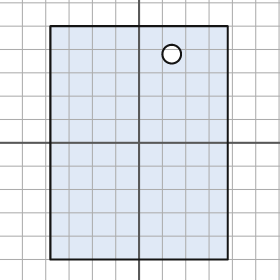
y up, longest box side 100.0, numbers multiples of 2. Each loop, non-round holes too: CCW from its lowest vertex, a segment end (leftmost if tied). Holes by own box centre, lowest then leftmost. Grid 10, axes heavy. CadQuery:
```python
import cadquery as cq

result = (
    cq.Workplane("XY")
    .moveTo(-38.0, -50.0)
    .lineTo(38.0, -50.0)
    .lineTo(38.0, 50.0)
    .lineTo(-38.0, 50.0)
    .close()
    .moveTo(14.0, 38.0)
    .circle(4.0)
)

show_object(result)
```